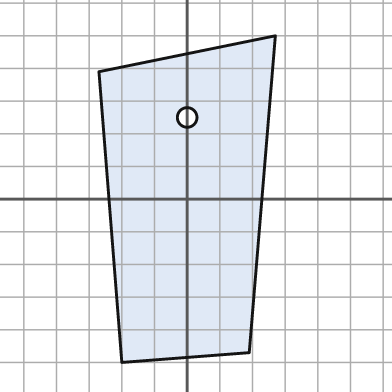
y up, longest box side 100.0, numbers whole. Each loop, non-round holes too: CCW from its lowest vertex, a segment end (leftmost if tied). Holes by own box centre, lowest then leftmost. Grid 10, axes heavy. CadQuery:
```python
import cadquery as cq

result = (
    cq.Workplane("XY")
    .moveTo(-20.0, -50.0)
    .lineTo(19.0, -47.0)
    .lineTo(27.0, 50.0)
    .lineTo(-27.0, 39.0)
    .close()
    .moveTo(0.0, 25.0)
    .circle(3.0)
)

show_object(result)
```